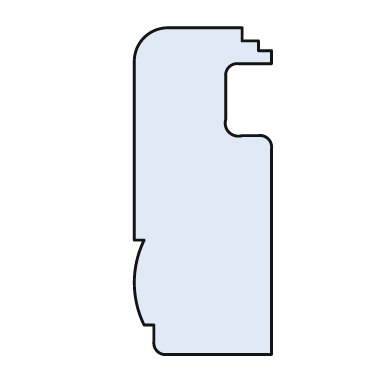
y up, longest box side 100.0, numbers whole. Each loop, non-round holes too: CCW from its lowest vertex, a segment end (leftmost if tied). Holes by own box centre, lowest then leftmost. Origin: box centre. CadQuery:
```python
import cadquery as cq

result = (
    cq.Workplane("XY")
    .moveTo(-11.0, -50.0)
    .lineTo(21.0, -50.0)
    .lineTo(21.0, 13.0)
    .threePointArc((20.0, 16.0), (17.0, 17.0))
    .lineTo(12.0, 17.0)
    .threePointArc((8.0, 18.0), (7.0, 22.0))
    .lineTo(7.0, 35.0)
    .threePointArc((8.0, 38.0), (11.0, 39.0))
    .lineTo(21.0, 39.0)
    .lineTo(21.0, 43.0)
    .lineTo(17.0, 43.0)
    .lineTo(17.0, 46.0)
    .lineTo(12.0, 46.0)
    .lineTo(12.0, 50.0)
    .lineTo(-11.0, 50.0)
    .threePointArc((-18.0, 47.0), (-21.0, 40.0))
    .lineTo(-21.0, -15.0)
    .lineTo(-18.0, -15.0)
    .threePointArc((-21.0, -28.0), (-18.0, -41.0))
    .lineTo(-15.0, -41.0)
    .lineTo(-15.0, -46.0)
    .threePointArc((-14.0, -49.0), (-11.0, -50.0))
    .close()
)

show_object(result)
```